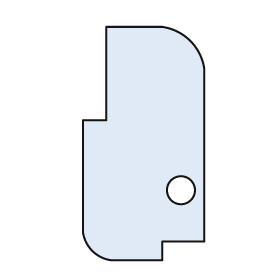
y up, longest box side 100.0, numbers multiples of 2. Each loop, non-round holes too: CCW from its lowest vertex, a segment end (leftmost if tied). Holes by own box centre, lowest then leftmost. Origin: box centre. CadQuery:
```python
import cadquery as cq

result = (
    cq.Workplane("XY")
    .moveTo(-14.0, -50.0)
    .lineTo(8.0, -50.0)
    .lineTo(8.0, -42.0)
    .lineTo(26.0, -42.0)
    .lineTo(26.0, 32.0)
    .threePointArc((20.0, 44.0), (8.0, 50.0))
    .lineTo(-16.0, 50.0)
    .lineTo(-16.0, 10.0)
    .lineTo(-26.0, 10.0)
    .lineTo(-26.0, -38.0)
    .threePointArc((-22.0, -46.0), (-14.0, -50.0))
    .close()
    .moveTo(16.0, -20.0)
    .circle(6.0)
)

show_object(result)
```